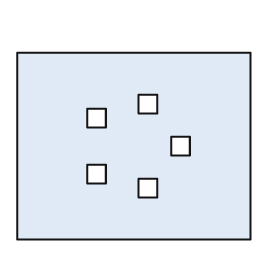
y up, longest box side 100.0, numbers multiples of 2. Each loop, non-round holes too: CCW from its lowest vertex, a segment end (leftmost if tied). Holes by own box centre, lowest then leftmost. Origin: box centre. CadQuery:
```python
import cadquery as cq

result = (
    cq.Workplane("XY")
    .moveTo(-50.0, -40.0)
    .lineTo(50.0, -40.0)
    .lineTo(50.0, 40.0)
    .lineTo(-50.0, 40.0)
    .close()
    .moveTo(2.0, -22.0)
    .lineTo(10.0, -22.0)
    .lineTo(10.0, -14.0)
    .lineTo(2.0, -14.0)
    .close()
    .moveTo(-20.0, -16.0)
    .lineTo(-12.0, -16.0)
    .lineTo(-12.0, -8.0)
    .lineTo(-20.0, -8.0)
    .close()
    .moveTo(16.0, -4.0)
    .lineTo(24.0, -4.0)
    .lineTo(24.0, 4.0)
    .lineTo(16.0, 4.0)
    .close()
    .moveTo(-20.0, 8.0)
    .lineTo(-12.0, 8.0)
    .lineTo(-12.0, 16.0)
    .lineTo(-20.0, 16.0)
    .close()
    .moveTo(2.0, 14.0)
    .lineTo(10.0, 14.0)
    .lineTo(10.0, 22.0)
    .lineTo(2.0, 22.0)
    .close()
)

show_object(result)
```